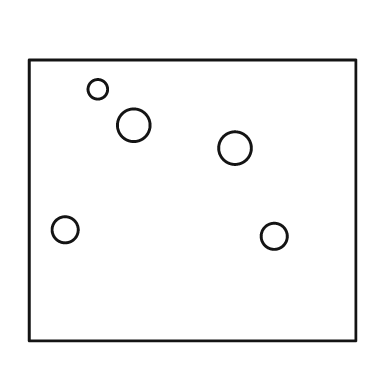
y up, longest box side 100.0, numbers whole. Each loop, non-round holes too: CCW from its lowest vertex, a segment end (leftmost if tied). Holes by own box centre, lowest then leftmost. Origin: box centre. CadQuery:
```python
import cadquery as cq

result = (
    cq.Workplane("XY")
    .moveTo(-50.0, -43.0)
    .lineTo(50.0, -43.0)
    .lineTo(50.0, 43.0)
    .lineTo(-50.0, 43.0)
    .close()
    .moveTo(25.0, -11.0)
    .circle(4.0)
    .moveTo(-39.0, -9.0)
    .circle(4.0)
    .moveTo(13.0, 16.0)
    .circle(5.0)
    .moveTo(-18.0, 23.0)
    .circle(5.0)
    .moveTo(-29.0, 34.0)
    .circle(3.0)
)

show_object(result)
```